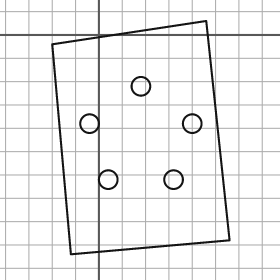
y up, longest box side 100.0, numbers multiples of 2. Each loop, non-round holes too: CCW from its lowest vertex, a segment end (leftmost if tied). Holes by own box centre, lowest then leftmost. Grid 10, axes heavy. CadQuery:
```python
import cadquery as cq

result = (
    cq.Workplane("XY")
    .moveTo(-12.0, -94.0)
    .lineTo(56.0, -88.0)
    .lineTo(46.0, 6.0)
    .lineTo(-20.0, -4.0)
    .close()
    .moveTo(4.0, -62.0)
    .circle(4.0)
    .moveTo(32.0, -62.0)
    .circle(4.0)
    .moveTo(-4.0, -38.0)
    .circle(4.0)
    .moveTo(40.0, -38.0)
    .circle(4.0)
    .moveTo(18.0, -22.0)
    .circle(4.0)
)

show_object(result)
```